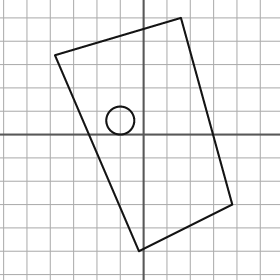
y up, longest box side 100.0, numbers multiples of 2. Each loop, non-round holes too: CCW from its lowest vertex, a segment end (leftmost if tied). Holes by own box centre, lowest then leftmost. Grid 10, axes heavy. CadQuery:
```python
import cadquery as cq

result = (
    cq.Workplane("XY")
    .moveTo(-2.0, -50.0)
    .lineTo(38.0, -30.0)
    .lineTo(16.0, 50.0)
    .lineTo(-38.0, 34.0)
    .close()
    .moveTo(-10.0, 6.0)
    .circle(6.0)
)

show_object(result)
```